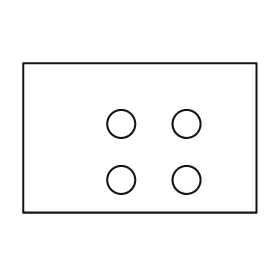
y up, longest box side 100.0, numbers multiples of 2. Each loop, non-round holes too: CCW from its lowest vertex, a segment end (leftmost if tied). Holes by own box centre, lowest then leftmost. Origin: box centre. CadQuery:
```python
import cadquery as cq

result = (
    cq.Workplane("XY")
    .moveTo(-50.0, -32.0)
    .lineTo(50.0, -32.0)
    .lineTo(50.0, 32.0)
    .lineTo(-50.0, 32.0)
    .close()
    .moveTo(-8.0, -18.0)
    .circle(6.0)
    .moveTo(20.0, -18.0)
    .circle(6.0)
    .moveTo(-8.0, 6.0)
    .circle(6.0)
    .moveTo(20.0, 6.0)
    .circle(6.0)
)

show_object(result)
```